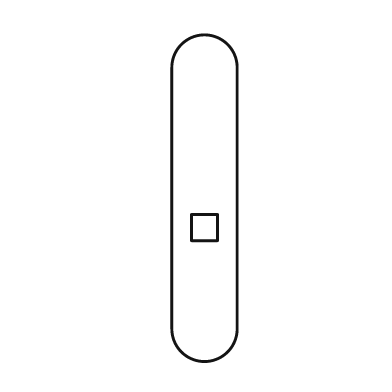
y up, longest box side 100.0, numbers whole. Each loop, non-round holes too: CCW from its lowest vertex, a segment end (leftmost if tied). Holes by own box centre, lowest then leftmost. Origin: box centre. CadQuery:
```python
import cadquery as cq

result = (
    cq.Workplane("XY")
    .moveTo(-10.0, -40.0)
    .threePointArc((0.0, -50.0), (10.0, -40.0))
    .lineTo(10.0, 40.0)
    .threePointArc((0.0, 50.0), (-10.0, 40.0))
    .close()
    .moveTo(-4.0, -13.0)
    .lineTo(4.0, -13.0)
    .lineTo(4.0, -5.0)
    .lineTo(-4.0, -5.0)
    .close()
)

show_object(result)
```